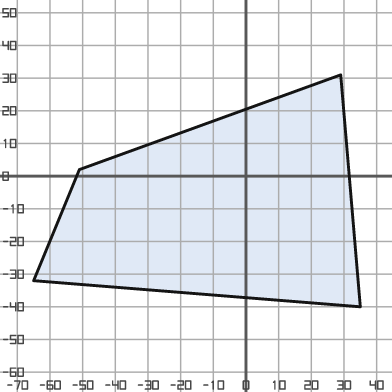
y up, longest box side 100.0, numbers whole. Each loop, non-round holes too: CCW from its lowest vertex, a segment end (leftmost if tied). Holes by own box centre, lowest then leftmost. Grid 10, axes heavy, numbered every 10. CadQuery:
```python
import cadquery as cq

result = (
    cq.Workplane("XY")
    .moveTo(35.0, -40.0)
    .lineTo(29.0, 31.0)
    .lineTo(-51.0, 2.0)
    .lineTo(-65.0, -32.0)
    .close()
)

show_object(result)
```